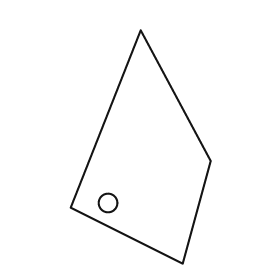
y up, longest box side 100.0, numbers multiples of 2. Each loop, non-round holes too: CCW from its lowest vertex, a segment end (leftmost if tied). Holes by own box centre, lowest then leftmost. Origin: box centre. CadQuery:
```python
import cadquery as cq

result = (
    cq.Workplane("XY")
    .moveTo(18.0, -50.0)
    .lineTo(30.0, -6.0)
    .lineTo(0.0, 50.0)
    .lineTo(-30.0, -26.0)
    .close()
    .moveTo(-14.0, -24.0)
    .circle(4.0)
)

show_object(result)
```